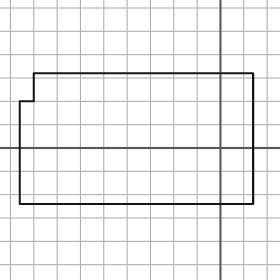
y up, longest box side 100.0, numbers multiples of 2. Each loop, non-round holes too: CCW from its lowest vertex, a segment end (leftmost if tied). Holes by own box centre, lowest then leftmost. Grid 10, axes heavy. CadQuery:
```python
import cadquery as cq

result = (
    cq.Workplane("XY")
    .moveTo(-86.0, -24.0)
    .lineTo(14.0, -24.0)
    .lineTo(14.0, 32.0)
    .lineTo(-80.0, 32.0)
    .lineTo(-80.0, 20.0)
    .lineTo(-86.0, 20.0)
    .close()
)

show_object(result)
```